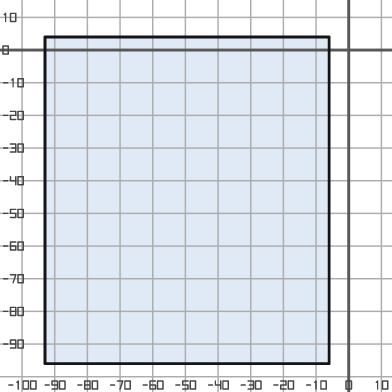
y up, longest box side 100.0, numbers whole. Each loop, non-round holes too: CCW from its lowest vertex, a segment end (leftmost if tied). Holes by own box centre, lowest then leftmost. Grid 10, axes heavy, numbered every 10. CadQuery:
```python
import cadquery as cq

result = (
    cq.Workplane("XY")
    .moveTo(-93.0, -96.0)
    .lineTo(-6.0, -96.0)
    .lineTo(-6.0, 4.0)
    .lineTo(-93.0, 4.0)
    .close()
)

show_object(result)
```